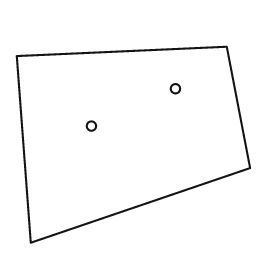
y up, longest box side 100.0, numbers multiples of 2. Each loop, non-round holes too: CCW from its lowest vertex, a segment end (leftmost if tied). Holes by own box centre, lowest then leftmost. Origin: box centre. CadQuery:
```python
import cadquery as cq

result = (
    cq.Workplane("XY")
    .moveTo(-44.0, -42.0)
    .lineTo(50.0, -10.0)
    .lineTo(40.0, 42.0)
    .lineTo(-50.0, 38.0)
    .close()
    .moveTo(-18.0, 8.0)
    .circle(2.0)
    .moveTo(18.0, 24.0)
    .circle(2.0)
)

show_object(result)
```